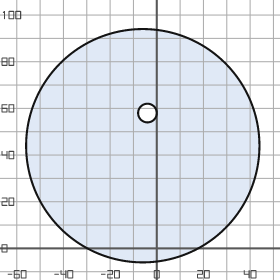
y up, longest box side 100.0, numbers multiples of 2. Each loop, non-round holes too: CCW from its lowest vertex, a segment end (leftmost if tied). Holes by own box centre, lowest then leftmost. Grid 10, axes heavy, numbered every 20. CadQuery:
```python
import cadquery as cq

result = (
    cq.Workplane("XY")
    .moveTo(-6.0, 44.0)
    .circle(50.0)
    .moveTo(-4.0, 58.0)
    .circle(4.0)
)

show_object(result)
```